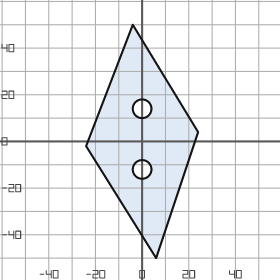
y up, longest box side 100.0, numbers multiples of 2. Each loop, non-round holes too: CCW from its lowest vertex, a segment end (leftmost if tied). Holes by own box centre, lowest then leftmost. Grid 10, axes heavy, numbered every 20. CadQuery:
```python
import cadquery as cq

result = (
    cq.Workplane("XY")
    .moveTo(6.0, -50.0)
    .lineTo(24.0, 4.0)
    .lineTo(-4.0, 50.0)
    .lineTo(-24.0, -2.0)
    .close()
    .moveTo(0.0, -12.0)
    .circle(4.0)
    .moveTo(0.0, 14.0)
    .circle(4.0)
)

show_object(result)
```